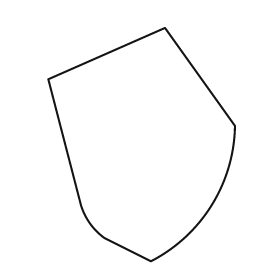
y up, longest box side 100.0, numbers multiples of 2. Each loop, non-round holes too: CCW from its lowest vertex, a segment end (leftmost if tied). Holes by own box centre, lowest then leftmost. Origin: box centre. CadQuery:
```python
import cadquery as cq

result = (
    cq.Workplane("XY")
    .moveTo(4.0, -50.0)
    .threePointArc((30.0, -26.0), (40.0, 8.0))
    .lineTo(10.0, 50.0)
    .lineTo(-40.0, 28.0)
    .lineTo(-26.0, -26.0)
    .threePointArc((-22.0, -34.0), (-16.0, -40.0))
    .close()
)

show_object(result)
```